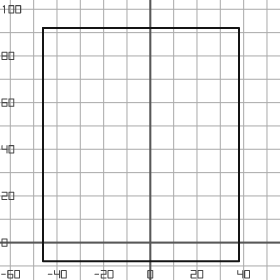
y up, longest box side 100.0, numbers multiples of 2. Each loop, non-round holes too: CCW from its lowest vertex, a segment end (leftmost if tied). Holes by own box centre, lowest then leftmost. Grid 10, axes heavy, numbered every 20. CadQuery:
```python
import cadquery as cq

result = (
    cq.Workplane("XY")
    .moveTo(-46.0, -8.0)
    .lineTo(38.0, -8.0)
    .lineTo(38.0, 92.0)
    .lineTo(-46.0, 92.0)
    .close()
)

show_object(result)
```